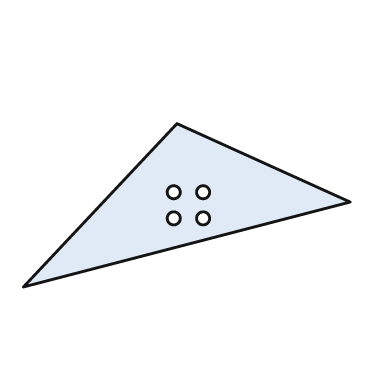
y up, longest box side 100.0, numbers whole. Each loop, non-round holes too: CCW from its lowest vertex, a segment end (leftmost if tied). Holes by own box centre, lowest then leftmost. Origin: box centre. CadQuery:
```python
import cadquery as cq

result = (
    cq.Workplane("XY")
    .moveTo(-50.0, -25.0)
    .lineTo(50.0, 1.0)
    .lineTo(-3.0, 25.0)
    .close()
    .moveTo(-4.0, -4.0)
    .circle(2.0)
    .moveTo(5.0, -4.0)
    .circle(2.0)
    .moveTo(-4.0, 4.0)
    .circle(2.0)
    .moveTo(5.0, 4.0)
    .circle(2.0)
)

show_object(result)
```